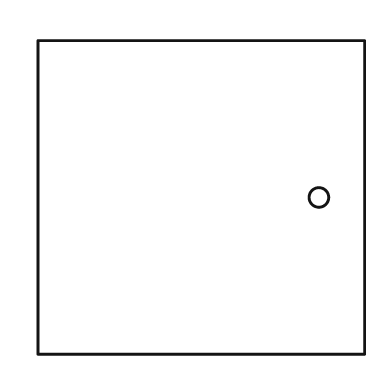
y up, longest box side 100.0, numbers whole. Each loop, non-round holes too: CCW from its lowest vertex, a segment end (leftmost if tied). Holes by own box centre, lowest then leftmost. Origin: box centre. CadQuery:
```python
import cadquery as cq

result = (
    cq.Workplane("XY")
    .moveTo(-50.0, -48.0)
    .lineTo(50.0, -48.0)
    .lineTo(50.0, 48.0)
    .lineTo(-50.0, 48.0)
    .close()
    .moveTo(36.0, 0.0)
    .circle(3.0)
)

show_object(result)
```